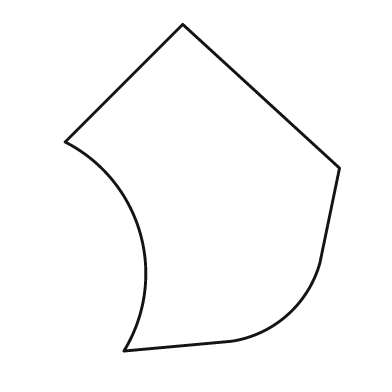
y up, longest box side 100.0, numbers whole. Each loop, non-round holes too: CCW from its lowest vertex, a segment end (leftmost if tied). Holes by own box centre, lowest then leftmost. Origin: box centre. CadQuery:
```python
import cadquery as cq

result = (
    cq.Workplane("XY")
    .moveTo(-24.0, -50.0)
    .lineTo(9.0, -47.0)
    .threePointArc((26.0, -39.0), (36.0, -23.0))
    .lineTo(42.0, 6.0)
    .lineTo(-6.0, 50.0)
    .lineTo(-42.0, 14.0)
    .threePointArc((-19.0, -14.0), (-24.0, -50.0))
    .close()
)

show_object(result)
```